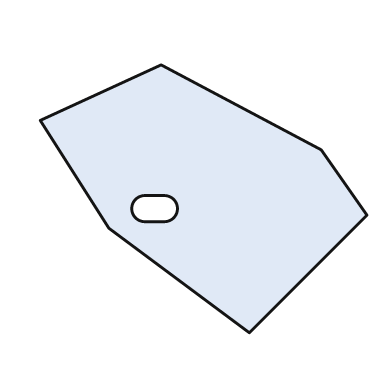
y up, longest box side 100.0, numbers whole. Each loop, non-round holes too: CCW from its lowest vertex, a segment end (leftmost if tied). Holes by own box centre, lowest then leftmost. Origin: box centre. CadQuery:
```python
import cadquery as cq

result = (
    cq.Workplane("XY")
    .moveTo(14.0, -41.0)
    .lineTo(50.0, -5.0)
    .lineTo(36.0, 15.0)
    .lineTo(-13.0, 41.0)
    .lineTo(-50.0, 24.0)
    .lineTo(-29.0, -9.0)
    .close()
    .moveTo(-18.0, -7.0)
    .lineTo(-12.0, -7.0)
    .threePointArc((-8.0, -3.0), (-12.0, 1.0))
    .lineTo(-18.0, 1.0)
    .threePointArc((-22.0, -3.0), (-18.0, -7.0))
    .close()
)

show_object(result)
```